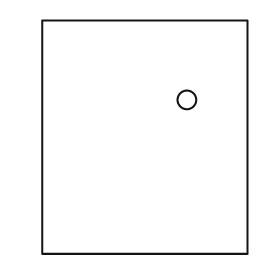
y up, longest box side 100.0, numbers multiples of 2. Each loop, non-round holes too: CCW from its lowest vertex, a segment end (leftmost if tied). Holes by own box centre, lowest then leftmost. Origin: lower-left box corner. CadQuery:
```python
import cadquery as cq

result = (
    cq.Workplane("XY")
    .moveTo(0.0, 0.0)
    .lineTo(88.0, 0.0)
    .lineTo(88.0, 100.0)
    .lineTo(0.0, 100.0)
    .close()
    .moveTo(62.0, 66.0)
    .circle(4.0)
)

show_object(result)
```